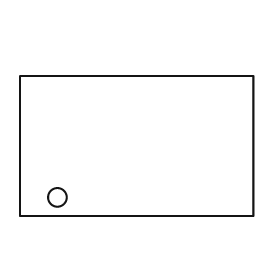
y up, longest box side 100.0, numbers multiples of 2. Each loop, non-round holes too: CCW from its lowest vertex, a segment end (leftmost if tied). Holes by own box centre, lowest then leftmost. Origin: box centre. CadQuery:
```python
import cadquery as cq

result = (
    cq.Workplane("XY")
    .moveTo(-50.0, -30.0)
    .lineTo(50.0, -30.0)
    .lineTo(50.0, 30.0)
    .lineTo(-50.0, 30.0)
    .close()
    .moveTo(-34.0, -22.0)
    .circle(4.0)
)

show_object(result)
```